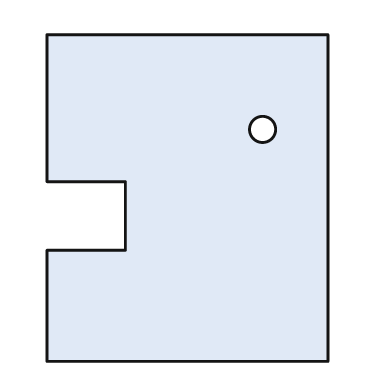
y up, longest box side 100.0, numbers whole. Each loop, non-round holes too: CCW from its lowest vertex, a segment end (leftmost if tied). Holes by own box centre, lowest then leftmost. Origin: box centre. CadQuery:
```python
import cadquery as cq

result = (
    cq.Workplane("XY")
    .moveTo(-43.0, -50.0)
    .lineTo(43.0, -50.0)
    .lineTo(43.0, 50.0)
    .lineTo(-43.0, 50.0)
    .lineTo(-43.0, 5.0)
    .lineTo(-19.0, 5.0)
    .lineTo(-19.0, -16.0)
    .lineTo(-43.0, -16.0)
    .close()
    .moveTo(23.0, 21.0)
    .circle(4.0)
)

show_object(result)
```